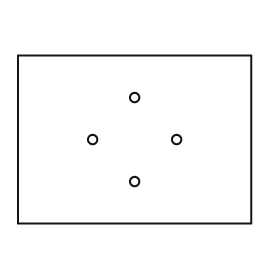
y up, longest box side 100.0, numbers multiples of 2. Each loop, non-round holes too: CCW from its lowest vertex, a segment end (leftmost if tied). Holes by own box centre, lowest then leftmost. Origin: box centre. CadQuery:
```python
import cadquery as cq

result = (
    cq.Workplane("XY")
    .moveTo(-50.0, -36.0)
    .lineTo(50.0, -36.0)
    .lineTo(50.0, 36.0)
    .lineTo(-50.0, 36.0)
    .close()
    .moveTo(0.0, -18.0)
    .circle(2.0)
    .moveTo(-18.0, 0.0)
    .circle(2.0)
    .moveTo(18.0, 0.0)
    .circle(2.0)
    .moveTo(0.0, 18.0)
    .circle(2.0)
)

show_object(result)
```